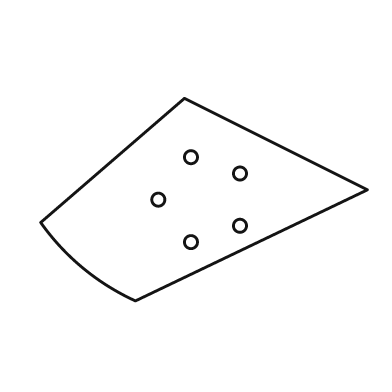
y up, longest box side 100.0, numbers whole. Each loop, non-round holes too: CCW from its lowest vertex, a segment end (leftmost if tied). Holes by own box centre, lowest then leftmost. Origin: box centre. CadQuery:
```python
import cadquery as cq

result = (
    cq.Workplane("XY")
    .moveTo(-21.0, -31.0)
    .lineTo(50.0, 3.0)
    .lineTo(-6.0, 31.0)
    .lineTo(-50.0, -7.0)
    .threePointArc((-37.0, -21.0), (-21.0, -31.0))
    .close()
    .moveTo(-4.0, -13.0)
    .circle(2.0)
    .moveTo(11.0, -8.0)
    .circle(2.0)
    .moveTo(-14.0, 0.0)
    .circle(2.0)
    .moveTo(11.0, 8.0)
    .circle(2.0)
    .moveTo(-4.0, 13.0)
    .circle(2.0)
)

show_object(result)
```